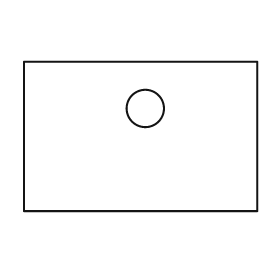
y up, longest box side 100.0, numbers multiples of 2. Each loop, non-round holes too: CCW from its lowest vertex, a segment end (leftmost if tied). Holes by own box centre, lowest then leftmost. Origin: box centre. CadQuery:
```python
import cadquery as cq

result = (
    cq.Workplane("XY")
    .moveTo(-50.0, -32.0)
    .lineTo(50.0, -32.0)
    .lineTo(50.0, 32.0)
    .lineTo(-50.0, 32.0)
    .close()
    .moveTo(2.0, 12.0)
    .circle(8.0)
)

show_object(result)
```